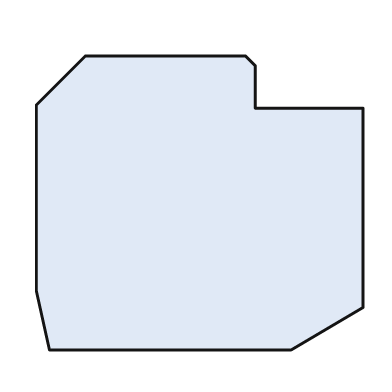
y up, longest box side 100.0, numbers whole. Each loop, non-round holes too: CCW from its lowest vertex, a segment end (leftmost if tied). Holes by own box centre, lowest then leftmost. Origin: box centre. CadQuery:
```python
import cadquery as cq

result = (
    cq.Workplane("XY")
    .moveTo(-46.0, -45.0)
    .lineTo(28.0, -45.0)
    .lineTo(50.0, -32.0)
    .lineTo(50.0, 29.0)
    .lineTo(17.0, 29.0)
    .lineTo(17.0, 42.0)
    .lineTo(14.0, 45.0)
    .lineTo(-35.0, 45.0)
    .lineTo(-50.0, 30.0)
    .lineTo(-50.0, -27.0)
    .close()
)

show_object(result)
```